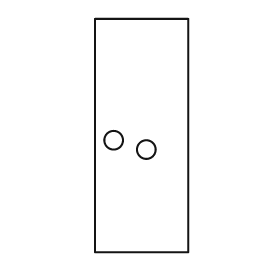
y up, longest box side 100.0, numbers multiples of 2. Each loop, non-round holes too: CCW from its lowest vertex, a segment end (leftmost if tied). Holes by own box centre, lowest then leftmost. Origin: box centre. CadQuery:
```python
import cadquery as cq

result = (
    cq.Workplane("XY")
    .moveTo(-20.0, -50.0)
    .lineTo(20.0, -50.0)
    .lineTo(20.0, 50.0)
    .lineTo(-20.0, 50.0)
    .close()
    .moveTo(2.0, -6.0)
    .circle(4.0)
    .moveTo(-12.0, -2.0)
    .circle(4.0)
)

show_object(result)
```